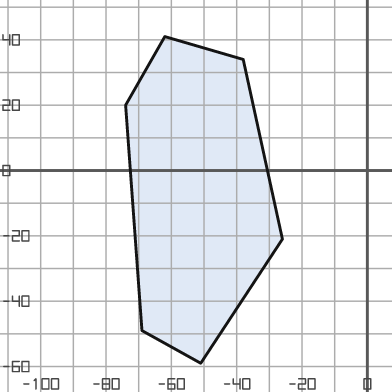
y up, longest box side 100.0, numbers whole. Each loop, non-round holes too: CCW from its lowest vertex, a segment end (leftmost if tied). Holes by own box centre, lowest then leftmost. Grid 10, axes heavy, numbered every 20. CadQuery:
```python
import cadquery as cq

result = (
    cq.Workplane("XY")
    .moveTo(-51.0, -59.0)
    .lineTo(-26.0, -21.0)
    .lineTo(-38.0, 34.0)
    .lineTo(-62.0, 41.0)
    .lineTo(-74.0, 20.0)
    .lineTo(-69.0, -49.0)
    .close()
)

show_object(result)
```